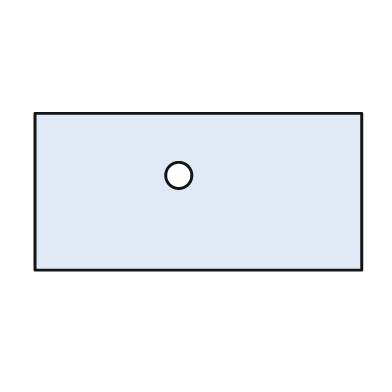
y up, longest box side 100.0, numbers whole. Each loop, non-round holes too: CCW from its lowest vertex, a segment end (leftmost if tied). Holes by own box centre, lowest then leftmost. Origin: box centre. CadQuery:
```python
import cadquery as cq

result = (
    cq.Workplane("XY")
    .moveTo(-50.0, -24.0)
    .lineTo(50.0, -24.0)
    .lineTo(50.0, 24.0)
    .lineTo(-50.0, 24.0)
    .close()
    .moveTo(-6.0, 5.0)
    .circle(4.0)
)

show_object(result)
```